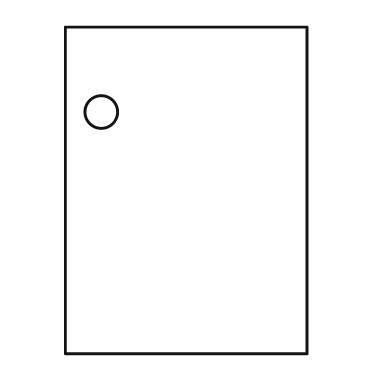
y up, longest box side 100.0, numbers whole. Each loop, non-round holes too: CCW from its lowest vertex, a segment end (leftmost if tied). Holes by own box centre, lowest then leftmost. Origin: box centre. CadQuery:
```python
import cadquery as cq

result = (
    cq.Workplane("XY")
    .moveTo(-37.0, -50.0)
    .lineTo(37.0, -50.0)
    .lineTo(37.0, 50.0)
    .lineTo(-37.0, 50.0)
    .close()
    .moveTo(-26.0, 24.0)
    .circle(5.0)
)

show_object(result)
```